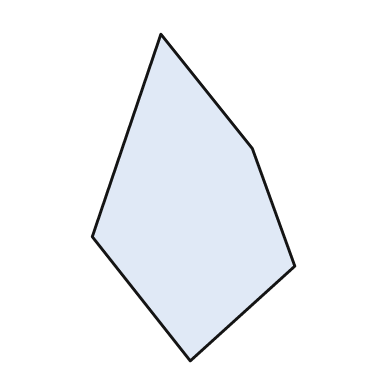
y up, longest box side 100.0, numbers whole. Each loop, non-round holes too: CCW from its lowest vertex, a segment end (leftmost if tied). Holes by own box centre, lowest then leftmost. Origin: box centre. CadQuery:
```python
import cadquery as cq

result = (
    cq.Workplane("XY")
    .moveTo(-1.0, -50.0)
    .lineTo(31.0, -21.0)
    .lineTo(18.0, 15.0)
    .lineTo(-10.0, 50.0)
    .lineTo(-31.0, -12.0)
    .close()
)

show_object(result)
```